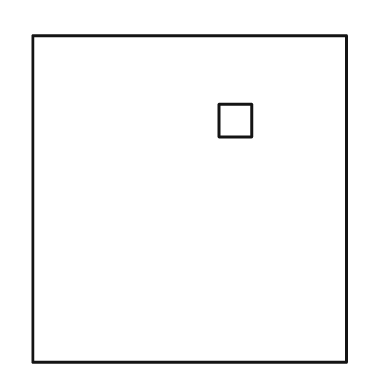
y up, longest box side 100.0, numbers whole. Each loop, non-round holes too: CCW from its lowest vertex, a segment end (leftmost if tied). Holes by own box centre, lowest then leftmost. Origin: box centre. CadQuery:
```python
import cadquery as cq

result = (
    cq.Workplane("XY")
    .moveTo(-48.0, -50.0)
    .lineTo(48.0, -50.0)
    .lineTo(48.0, 50.0)
    .lineTo(-48.0, 50.0)
    .close()
    .moveTo(9.0, 19.0)
    .lineTo(19.0, 19.0)
    .lineTo(19.0, 29.0)
    .lineTo(9.0, 29.0)
    .close()
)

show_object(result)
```